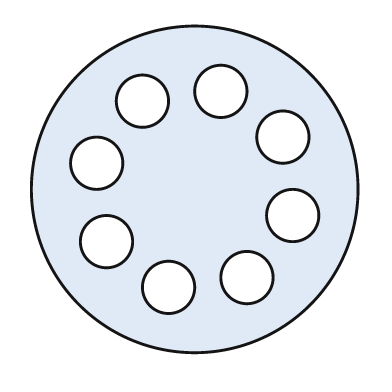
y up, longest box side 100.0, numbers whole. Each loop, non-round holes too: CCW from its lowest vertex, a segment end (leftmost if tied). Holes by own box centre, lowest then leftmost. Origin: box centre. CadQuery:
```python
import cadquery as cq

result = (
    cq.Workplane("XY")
    .moveTo(0.0, 0.0)
    .circle(50.0)
    .moveTo(-8.0, -30.0)
    .circle(8.0)
    .moveTo(16.0, -27.0)
    .circle(8.0)
    .moveTo(-27.0, -16.0)
    .circle(8.0)
    .moveTo(30.0, -8.0)
    .circle(8.0)
    .moveTo(-30.0, 8.0)
    .circle(8.0)
    .moveTo(27.0, 16.0)
    .circle(8.0)
    .moveTo(-16.0, 27.0)
    .circle(8.0)
    .moveTo(8.0, 30.0)
    .circle(8.0)
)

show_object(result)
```